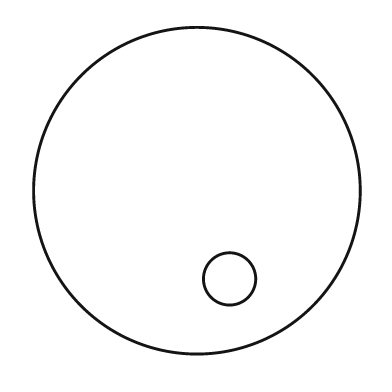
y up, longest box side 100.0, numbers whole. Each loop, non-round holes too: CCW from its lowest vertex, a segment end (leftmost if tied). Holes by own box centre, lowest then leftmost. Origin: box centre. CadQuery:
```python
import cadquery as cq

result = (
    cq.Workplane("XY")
    .moveTo(0.0, 0.0)
    .circle(50.0)
    .moveTo(10.0, -27.0)
    .circle(8.0)
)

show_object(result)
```